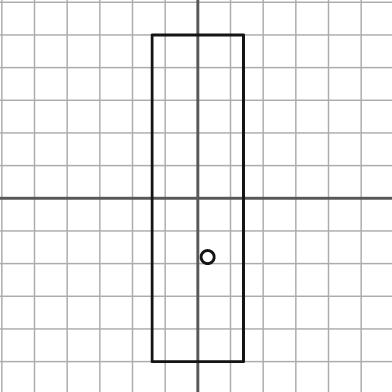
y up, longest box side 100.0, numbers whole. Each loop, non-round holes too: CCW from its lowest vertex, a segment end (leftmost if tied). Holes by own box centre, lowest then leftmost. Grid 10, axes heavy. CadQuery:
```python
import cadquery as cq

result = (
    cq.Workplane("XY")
    .moveTo(-14.0, -50.0)
    .lineTo(14.0, -50.0)
    .lineTo(14.0, 50.0)
    .lineTo(-14.0, 50.0)
    .close()
    .moveTo(3.0, -18.0)
    .circle(2.0)
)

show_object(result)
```